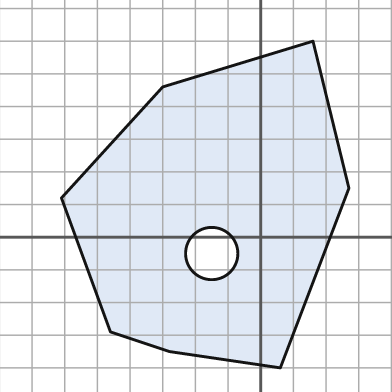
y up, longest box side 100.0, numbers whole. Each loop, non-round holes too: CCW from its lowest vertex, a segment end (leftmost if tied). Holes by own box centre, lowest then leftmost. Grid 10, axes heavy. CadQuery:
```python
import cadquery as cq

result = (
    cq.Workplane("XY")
    .moveTo(6.0, -40.0)
    .lineTo(27.0, 15.0)
    .lineTo(16.0, 60.0)
    .lineTo(-30.0, 46.0)
    .lineTo(-61.0, 12.0)
    .lineTo(-46.0, -29.0)
    .lineTo(-28.0, -35.0)
    .close()
    .moveTo(-15.0, -5.0)
    .circle(8.0)
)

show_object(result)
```